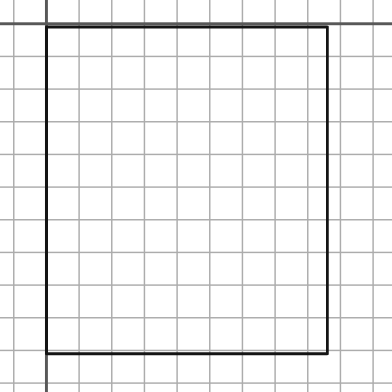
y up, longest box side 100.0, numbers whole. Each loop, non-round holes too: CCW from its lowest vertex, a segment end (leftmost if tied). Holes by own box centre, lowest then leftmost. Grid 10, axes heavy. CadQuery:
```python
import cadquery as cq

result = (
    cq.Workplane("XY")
    .moveTo(0.0, -101.0)
    .lineTo(86.0, -101.0)
    .lineTo(86.0, -1.0)
    .lineTo(0.0, -1.0)
    .close()
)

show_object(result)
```